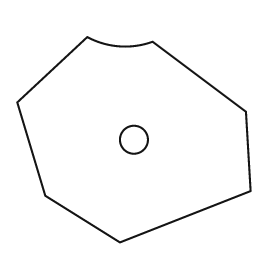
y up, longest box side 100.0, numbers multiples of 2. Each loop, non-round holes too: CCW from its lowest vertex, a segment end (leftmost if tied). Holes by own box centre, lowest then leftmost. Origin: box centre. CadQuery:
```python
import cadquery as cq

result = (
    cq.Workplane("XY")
    .moveTo(-6.0, -44.0)
    .lineTo(50.0, -22.0)
    .lineTo(48.0, 12.0)
    .lineTo(8.0, 42.0)
    .threePointArc((-6.0, 40.0), (-20.0, 44.0))
    .lineTo(-50.0, 16.0)
    .lineTo(-38.0, -24.0)
    .close()
    .moveTo(0.0, 0.0)
    .circle(6.0)
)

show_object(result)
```